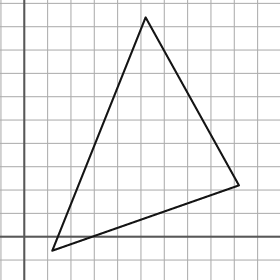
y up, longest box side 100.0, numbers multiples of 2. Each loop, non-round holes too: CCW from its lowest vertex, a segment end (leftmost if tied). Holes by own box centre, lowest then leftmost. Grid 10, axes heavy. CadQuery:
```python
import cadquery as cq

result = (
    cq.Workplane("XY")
    .moveTo(12.0, -6.0)
    .lineTo(92.0, 22.0)
    .lineTo(52.0, 94.0)
    .close()
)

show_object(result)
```